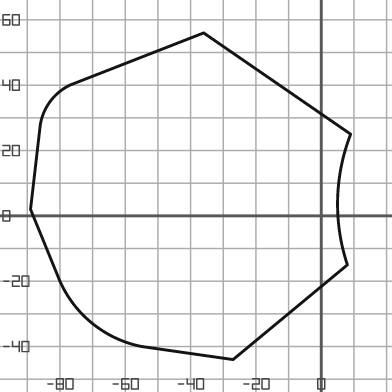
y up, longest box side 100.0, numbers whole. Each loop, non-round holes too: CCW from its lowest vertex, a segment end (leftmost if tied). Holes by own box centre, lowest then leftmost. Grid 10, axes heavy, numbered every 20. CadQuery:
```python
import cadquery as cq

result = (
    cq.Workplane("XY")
    .moveTo(-27.0, -44.0)
    .lineTo(8.0, -15.0)
    .threePointArc((5.0, 5.0), (9.0, 25.0))
    .lineTo(-36.0, 56.0)
    .lineTo(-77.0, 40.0)
    .threePointArc((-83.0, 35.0), (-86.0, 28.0))
    .lineTo(-89.0, 2.0)
    .lineTo(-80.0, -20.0)
    .threePointArc((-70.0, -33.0), (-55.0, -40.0))
    .close()
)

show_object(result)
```